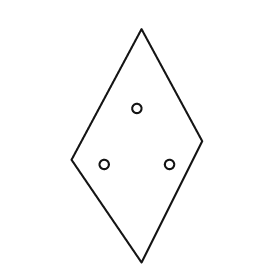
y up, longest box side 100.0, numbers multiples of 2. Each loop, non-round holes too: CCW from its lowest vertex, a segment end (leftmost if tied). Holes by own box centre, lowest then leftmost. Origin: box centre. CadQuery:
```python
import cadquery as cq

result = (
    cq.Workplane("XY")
    .moveTo(2.0, -50.0)
    .lineTo(28.0, 2.0)
    .lineTo(2.0, 50.0)
    .lineTo(-28.0, -6.0)
    .close()
    .moveTo(-14.0, -8.0)
    .circle(2.0)
    .moveTo(14.0, -8.0)
    .circle(2.0)
    .moveTo(0.0, 16.0)
    .circle(2.0)
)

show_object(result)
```